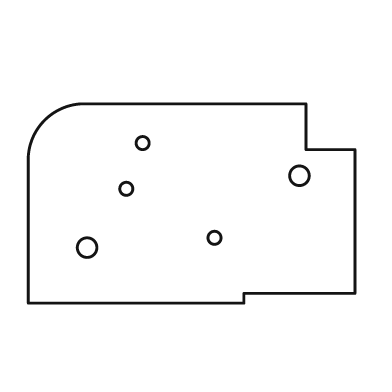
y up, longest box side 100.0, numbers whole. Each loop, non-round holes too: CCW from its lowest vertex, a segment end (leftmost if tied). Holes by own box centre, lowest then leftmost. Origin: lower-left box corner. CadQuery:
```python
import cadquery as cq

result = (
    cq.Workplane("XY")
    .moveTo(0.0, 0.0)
    .lineTo(66.0, 0.0)
    .lineTo(66.0, 3.0)
    .lineTo(100.0, 3.0)
    .lineTo(100.0, 47.0)
    .lineTo(85.0, 47.0)
    .lineTo(85.0, 61.0)
    .lineTo(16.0, 61.0)
    .threePointArc((5.0, 56.0), (0.0, 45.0))
    .close()
    .moveTo(18.0, 17.0)
    .circle(3.0)
    .moveTo(57.0, 20.0)
    .circle(2.0)
    .moveTo(30.0, 35.0)
    .circle(2.0)
    .moveTo(83.0, 39.0)
    .circle(3.0)
    .moveTo(35.0, 49.0)
    .circle(2.0)
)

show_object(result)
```